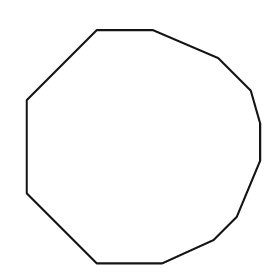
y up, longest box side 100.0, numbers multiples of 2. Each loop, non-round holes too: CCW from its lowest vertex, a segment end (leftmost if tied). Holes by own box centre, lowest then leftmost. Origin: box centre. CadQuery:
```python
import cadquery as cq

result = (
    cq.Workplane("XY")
    .moveTo(-20.0, -50.0)
    .lineTo(8.0, -50.0)
    .lineTo(30.0, -40.0)
    .lineTo(40.0, -30.0)
    .lineTo(50.0, -6.0)
    .lineTo(50.0, 10.0)
    .lineTo(46.0, 24.0)
    .lineTo(32.0, 38.0)
    .lineTo(4.0, 50.0)
    .lineTo(-20.0, 50.0)
    .lineTo(-50.0, 20.0)
    .lineTo(-50.0, -20.0)
    .close()
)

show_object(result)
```